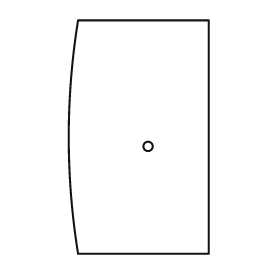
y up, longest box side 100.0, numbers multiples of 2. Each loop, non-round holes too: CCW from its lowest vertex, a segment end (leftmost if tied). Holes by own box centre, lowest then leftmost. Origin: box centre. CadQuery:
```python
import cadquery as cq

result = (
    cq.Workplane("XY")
    .moveTo(-26.0, -50.0)
    .lineTo(30.0, -50.0)
    .lineTo(30.0, 50.0)
    .lineTo(-26.0, 50.0)
    .threePointArc((-30.0, 0.0), (-26.0, -50.0))
    .close()
    .moveTo(4.0, -4.0)
    .circle(2.0)
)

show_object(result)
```